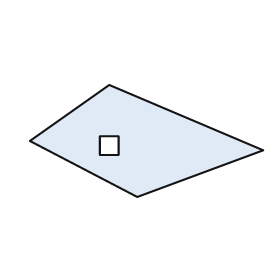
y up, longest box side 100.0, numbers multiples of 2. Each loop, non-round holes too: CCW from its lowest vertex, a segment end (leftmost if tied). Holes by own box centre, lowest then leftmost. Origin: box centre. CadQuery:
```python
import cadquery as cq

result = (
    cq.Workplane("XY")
    .moveTo(-4.0, -24.0)
    .lineTo(50.0, -4.0)
    .lineTo(-16.0, 24.0)
    .lineTo(-50.0, 0.0)
    .close()
    .moveTo(-20.0, -6.0)
    .lineTo(-12.0, -6.0)
    .lineTo(-12.0, 2.0)
    .lineTo(-20.0, 2.0)
    .close()
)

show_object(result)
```